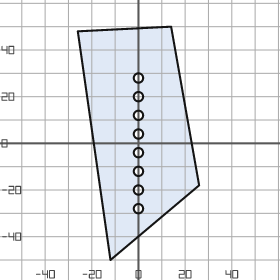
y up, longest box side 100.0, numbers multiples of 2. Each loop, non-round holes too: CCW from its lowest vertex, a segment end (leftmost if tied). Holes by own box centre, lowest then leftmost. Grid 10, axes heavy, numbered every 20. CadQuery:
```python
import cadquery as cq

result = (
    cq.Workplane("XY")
    .moveTo(-12.0, -50.0)
    .lineTo(26.0, -18.0)
    .lineTo(14.0, 50.0)
    .lineTo(-26.0, 48.0)
    .close()
    .moveTo(0.0, -28.0)
    .circle(2.0)
    .moveTo(0.0, -20.0)
    .circle(2.0)
    .moveTo(0.0, -12.0)
    .circle(2.0)
    .moveTo(0.0, -4.0)
    .circle(2.0)
    .moveTo(0.0, 4.0)
    .circle(2.0)
    .moveTo(0.0, 12.0)
    .circle(2.0)
    .moveTo(0.0, 20.0)
    .circle(2.0)
    .moveTo(0.0, 28.0)
    .circle(2.0)
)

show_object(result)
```